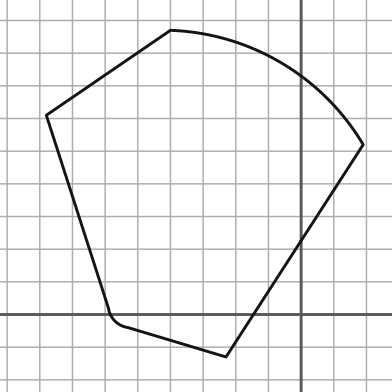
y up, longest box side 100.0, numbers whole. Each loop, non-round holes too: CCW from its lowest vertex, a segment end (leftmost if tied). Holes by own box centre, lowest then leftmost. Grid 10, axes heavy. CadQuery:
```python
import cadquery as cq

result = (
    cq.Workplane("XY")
    .moveTo(-23.0, -13.0)
    .lineTo(19.0, 52.0)
    .threePointArc((-6.0, 77.0), (-40.0, 87.0))
    .lineTo(-78.0, 61.0)
    .lineTo(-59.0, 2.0)
    .threePointArc((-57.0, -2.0), (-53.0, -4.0))
    .close()
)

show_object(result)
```